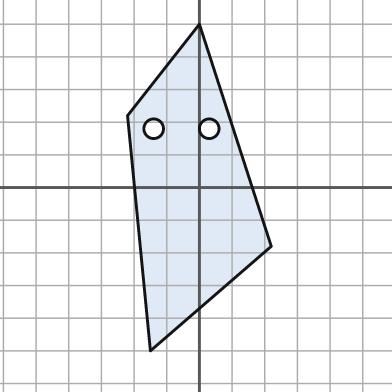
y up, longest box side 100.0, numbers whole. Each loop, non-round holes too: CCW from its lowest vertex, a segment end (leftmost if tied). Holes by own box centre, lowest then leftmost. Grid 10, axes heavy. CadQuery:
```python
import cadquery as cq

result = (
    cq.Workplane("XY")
    .moveTo(-15.0, -50.0)
    .lineTo(22.0, -18.0)
    .lineTo(0.0, 50.0)
    .lineTo(-22.0, 22.0)
    .close()
    .moveTo(-14.0, 18.0)
    .circle(3.0)
    .moveTo(3.0, 18.0)
    .circle(3.0)
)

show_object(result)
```